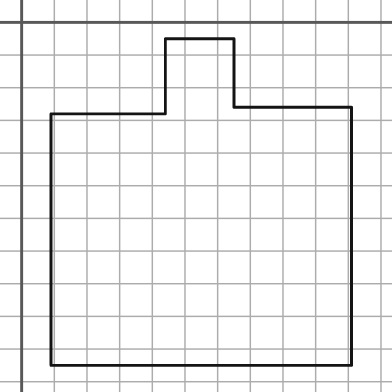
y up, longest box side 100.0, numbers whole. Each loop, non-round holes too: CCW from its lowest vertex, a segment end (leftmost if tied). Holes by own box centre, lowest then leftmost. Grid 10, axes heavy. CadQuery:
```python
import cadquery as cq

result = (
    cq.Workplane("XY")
    .moveTo(9.0, -105.0)
    .lineTo(101.0, -105.0)
    .lineTo(101.0, -26.0)
    .lineTo(65.0, -26.0)
    .lineTo(65.0, -5.0)
    .lineTo(44.0, -5.0)
    .lineTo(44.0, -28.0)
    .lineTo(9.0, -28.0)
    .close()
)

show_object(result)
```